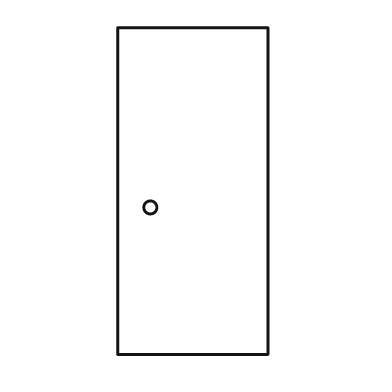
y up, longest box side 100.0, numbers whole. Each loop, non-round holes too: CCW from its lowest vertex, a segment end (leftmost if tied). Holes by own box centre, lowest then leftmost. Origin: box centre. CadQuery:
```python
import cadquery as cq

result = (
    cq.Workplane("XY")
    .moveTo(-23.0, -50.0)
    .lineTo(23.0, -50.0)
    .lineTo(23.0, 50.0)
    .lineTo(-23.0, 50.0)
    .close()
    .moveTo(-13.0, -5.0)
    .circle(2.0)
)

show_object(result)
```